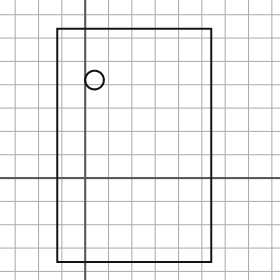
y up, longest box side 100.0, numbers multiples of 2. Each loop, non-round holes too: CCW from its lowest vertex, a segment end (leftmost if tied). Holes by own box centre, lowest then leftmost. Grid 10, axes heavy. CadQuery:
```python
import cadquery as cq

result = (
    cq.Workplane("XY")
    .moveTo(-12.0, -36.0)
    .lineTo(54.0, -36.0)
    .lineTo(54.0, 64.0)
    .lineTo(-12.0, 64.0)
    .close()
    .moveTo(4.0, 42.0)
    .circle(4.0)
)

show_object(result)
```